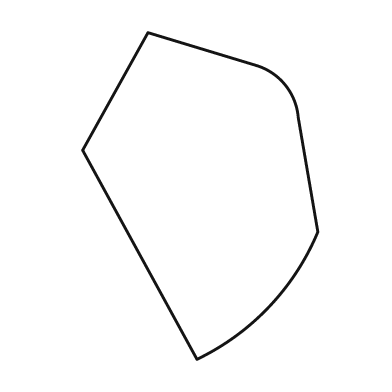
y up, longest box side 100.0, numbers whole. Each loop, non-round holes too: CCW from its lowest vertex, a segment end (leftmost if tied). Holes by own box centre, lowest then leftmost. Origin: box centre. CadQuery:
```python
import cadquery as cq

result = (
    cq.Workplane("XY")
    .moveTo(-1.0, -50.0)
    .threePointArc((21.0, -34.0), (36.0, -11.0))
    .lineTo(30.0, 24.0)
    .threePointArc((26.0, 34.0), (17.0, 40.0))
    .lineTo(-16.0, 50.0)
    .lineTo(-36.0, 14.0)
    .close()
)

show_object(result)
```